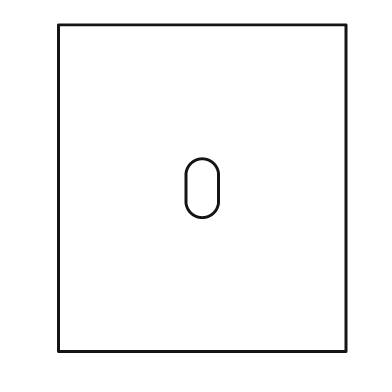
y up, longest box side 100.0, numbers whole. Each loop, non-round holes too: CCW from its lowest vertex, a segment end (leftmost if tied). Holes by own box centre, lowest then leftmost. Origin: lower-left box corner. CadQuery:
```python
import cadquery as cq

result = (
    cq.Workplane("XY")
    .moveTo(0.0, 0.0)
    .lineTo(88.0, 0.0)
    .lineTo(88.0, 100.0)
    .lineTo(0.0, 100.0)
    .close()
    .moveTo(39.0, 46.0)
    .threePointArc((44.0, 41.0), (49.0, 46.0))
    .lineTo(49.0, 54.0)
    .threePointArc((44.0, 59.0), (39.0, 54.0))
    .close()
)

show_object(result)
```